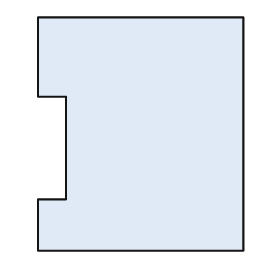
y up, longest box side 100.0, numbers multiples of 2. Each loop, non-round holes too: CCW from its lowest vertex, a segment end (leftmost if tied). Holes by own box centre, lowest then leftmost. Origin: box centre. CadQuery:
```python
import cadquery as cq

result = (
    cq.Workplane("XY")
    .moveTo(-44.0, -50.0)
    .lineTo(44.0, -50.0)
    .lineTo(44.0, 50.0)
    .lineTo(-44.0, 50.0)
    .lineTo(-44.0, 16.0)
    .lineTo(-32.0, 16.0)
    .lineTo(-32.0, -28.0)
    .lineTo(-44.0, -28.0)
    .close()
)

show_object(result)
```